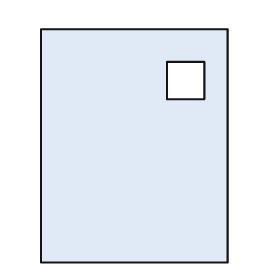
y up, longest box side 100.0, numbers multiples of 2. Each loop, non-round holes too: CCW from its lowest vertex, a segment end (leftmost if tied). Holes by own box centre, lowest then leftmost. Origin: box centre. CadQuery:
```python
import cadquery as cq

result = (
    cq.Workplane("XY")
    .moveTo(-40.0, -50.0)
    .lineTo(40.0, -50.0)
    .lineTo(40.0, 50.0)
    .lineTo(-40.0, 50.0)
    .close()
    .moveTo(14.0, 20.0)
    .lineTo(30.0, 20.0)
    .lineTo(30.0, 36.0)
    .lineTo(14.0, 36.0)
    .close()
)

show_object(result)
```